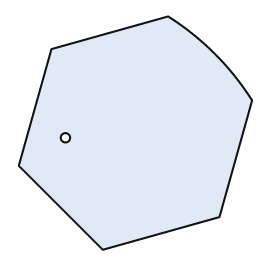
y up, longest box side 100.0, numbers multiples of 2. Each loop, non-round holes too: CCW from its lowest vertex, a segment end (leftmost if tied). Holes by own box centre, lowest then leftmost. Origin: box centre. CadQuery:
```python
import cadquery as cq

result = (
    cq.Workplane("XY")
    .moveTo(-14.0, -50.0)
    .lineTo(36.0, -36.0)
    .lineTo(50.0, 14.0)
    .threePointArc((34.0, 34.0), (14.0, 50.0))
    .lineTo(-36.0, 36.0)
    .lineTo(-50.0, -14.0)
    .close()
    .moveTo(-30.0, -2.0)
    .circle(2.0)
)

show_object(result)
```